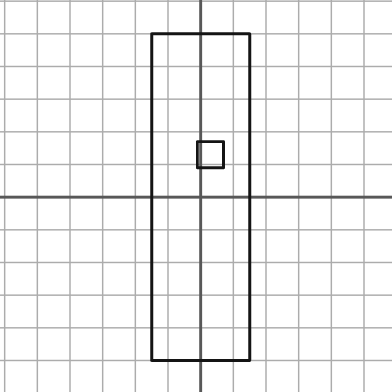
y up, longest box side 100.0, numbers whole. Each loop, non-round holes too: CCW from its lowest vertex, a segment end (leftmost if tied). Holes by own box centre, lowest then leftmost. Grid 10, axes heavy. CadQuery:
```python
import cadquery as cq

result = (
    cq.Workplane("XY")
    .moveTo(-15.0, -50.0)
    .lineTo(15.0, -50.0)
    .lineTo(15.0, 50.0)
    .lineTo(-15.0, 50.0)
    .close()
    .moveTo(-1.0, 9.0)
    .lineTo(7.0, 9.0)
    .lineTo(7.0, 17.0)
    .lineTo(-1.0, 17.0)
    .close()
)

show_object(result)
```